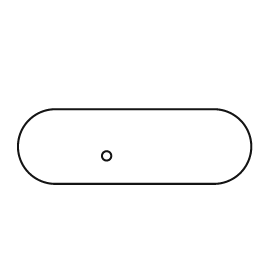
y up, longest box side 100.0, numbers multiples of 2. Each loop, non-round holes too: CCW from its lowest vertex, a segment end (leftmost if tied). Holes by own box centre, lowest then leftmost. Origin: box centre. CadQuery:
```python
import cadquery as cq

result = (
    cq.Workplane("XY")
    .moveTo(-34.0, -16.0)
    .lineTo(34.0, -16.0)
    .threePointArc((50.0, 0.0), (34.0, 16.0))
    .lineTo(-34.0, 16.0)
    .threePointArc((-50.0, 0.0), (-34.0, -16.0))
    .close()
    .moveTo(-12.0, -4.0)
    .circle(2.0)
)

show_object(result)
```